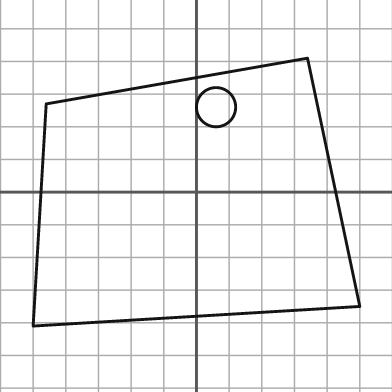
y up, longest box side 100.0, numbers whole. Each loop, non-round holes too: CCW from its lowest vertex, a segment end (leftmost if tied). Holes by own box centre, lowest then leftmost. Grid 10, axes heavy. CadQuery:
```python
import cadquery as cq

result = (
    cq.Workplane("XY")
    .moveTo(-50.0, -41.0)
    .lineTo(50.0, -35.0)
    .lineTo(34.0, 41.0)
    .lineTo(-46.0, 27.0)
    .close()
    .moveTo(6.0, 26.0)
    .circle(6.0)
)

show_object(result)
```